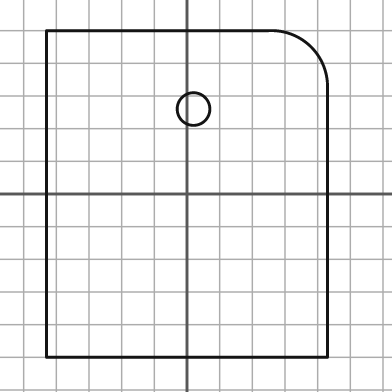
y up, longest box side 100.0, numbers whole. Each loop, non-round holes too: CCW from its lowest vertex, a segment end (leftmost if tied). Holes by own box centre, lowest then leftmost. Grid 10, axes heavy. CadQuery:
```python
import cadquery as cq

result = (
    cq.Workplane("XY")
    .moveTo(-43.0, -50.0)
    .lineTo(43.0, -50.0)
    .lineTo(43.0, 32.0)
    .threePointArc((38.0, 45.0), (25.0, 50.0))
    .lineTo(-43.0, 50.0)
    .close()
    .moveTo(2.0, 26.0)
    .circle(5.0)
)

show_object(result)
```